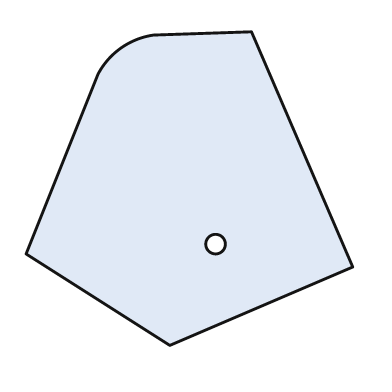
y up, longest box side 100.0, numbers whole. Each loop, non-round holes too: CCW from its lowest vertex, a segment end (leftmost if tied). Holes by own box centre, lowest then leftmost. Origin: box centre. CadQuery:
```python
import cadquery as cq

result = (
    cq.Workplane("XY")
    .moveTo(-6.0, -48.0)
    .lineTo(50.0, -24.0)
    .lineTo(19.0, 48.0)
    .lineTo(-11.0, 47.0)
    .threePointArc((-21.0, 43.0), (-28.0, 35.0))
    .lineTo(-50.0, -20.0)
    .close()
    .moveTo(8.0, -17.0)
    .circle(3.0)
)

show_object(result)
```